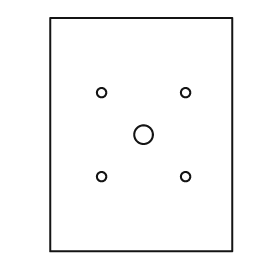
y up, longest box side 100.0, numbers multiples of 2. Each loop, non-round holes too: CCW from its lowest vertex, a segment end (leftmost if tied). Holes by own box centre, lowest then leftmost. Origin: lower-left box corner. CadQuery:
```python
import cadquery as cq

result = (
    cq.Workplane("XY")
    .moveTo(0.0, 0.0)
    .lineTo(78.0, 0.0)
    .lineTo(78.0, 100.0)
    .lineTo(0.0, 100.0)
    .close()
    .moveTo(22.0, 32.0)
    .circle(2.0)
    .moveTo(58.0, 32.0)
    .circle(2.0)
    .moveTo(40.0, 50.0)
    .circle(4.0)
    .moveTo(22.0, 68.0)
    .circle(2.0)
    .moveTo(58.0, 68.0)
    .circle(2.0)
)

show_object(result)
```